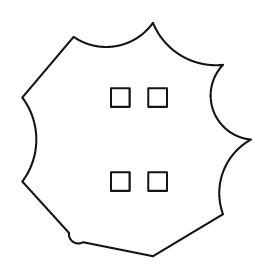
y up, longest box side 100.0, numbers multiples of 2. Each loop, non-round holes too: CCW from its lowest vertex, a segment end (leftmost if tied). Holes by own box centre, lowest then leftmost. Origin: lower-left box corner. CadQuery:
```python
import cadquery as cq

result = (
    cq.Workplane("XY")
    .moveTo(56.0, 0.0)
    .lineTo(86.0, 18.0)
    .threePointArc((86.0, 36.0), (98.0, 50.0))
    .threePointArc((82.0, 62.0), (86.0, 82.0))
    .threePointArc((68.0, 86.0), (56.0, 100.0))
    .threePointArc((40.0, 90.0), (22.0, 94.0))
    .lineTo(0.0, 68.0)
    .threePointArc((6.0, 50.0), (0.0, 32.0))
    .lineTo(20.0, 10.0)
    .threePointArc((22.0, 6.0), (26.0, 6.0))
    .close()
    .moveTo(38.0, 28.0)
    .lineTo(46.0, 28.0)
    .lineTo(46.0, 36.0)
    .lineTo(38.0, 36.0)
    .close()
    .moveTo(54.0, 28.0)
    .lineTo(62.0, 28.0)
    .lineTo(62.0, 36.0)
    .lineTo(54.0, 36.0)
    .close()
    .moveTo(38.0, 64.0)
    .lineTo(46.0, 64.0)
    .lineTo(46.0, 72.0)
    .lineTo(38.0, 72.0)
    .close()
    .moveTo(54.0, 64.0)
    .lineTo(62.0, 64.0)
    .lineTo(62.0, 72.0)
    .lineTo(54.0, 72.0)
    .close()
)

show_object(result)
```